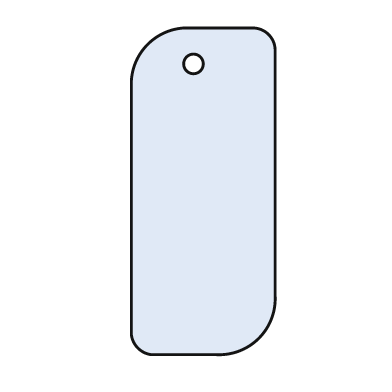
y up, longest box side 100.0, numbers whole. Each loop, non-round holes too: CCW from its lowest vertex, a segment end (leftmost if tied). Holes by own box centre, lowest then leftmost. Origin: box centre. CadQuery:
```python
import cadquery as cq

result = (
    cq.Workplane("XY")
    .moveTo(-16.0, -50.0)
    .lineTo(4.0, -50.0)
    .threePointArc((17.0, -45.0), (22.0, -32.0))
    .lineTo(22.0, 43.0)
    .threePointArc((20.0, 48.0), (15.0, 50.0))
    .lineTo(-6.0, 50.0)
    .threePointArc((-17.0, 45.0), (-22.0, 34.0))
    .lineTo(-22.0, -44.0)
    .threePointArc((-20.0, -48.0), (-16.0, -50.0))
    .close()
    .moveTo(-3.0, 39.0)
    .circle(3.0)
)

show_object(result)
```